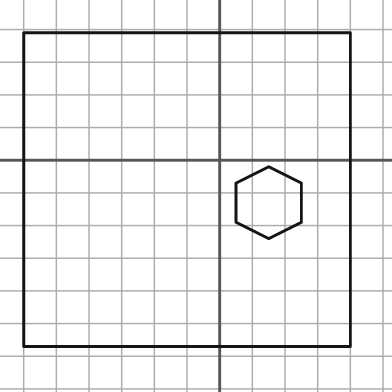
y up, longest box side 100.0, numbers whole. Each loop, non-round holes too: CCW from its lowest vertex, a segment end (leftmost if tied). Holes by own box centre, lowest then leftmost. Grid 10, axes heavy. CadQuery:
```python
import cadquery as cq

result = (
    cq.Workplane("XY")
    .moveTo(-60.0, -57.0)
    .lineTo(40.0, -57.0)
    .lineTo(40.0, 39.0)
    .lineTo(-60.0, 39.0)
    .close()
    .moveTo(15.0, -24.0)
    .lineTo(25.0, -19.0)
    .lineTo(25.0, -7.0)
    .lineTo(15.0, -2.0)
    .lineTo(5.0, -7.0)
    .lineTo(5.0, -19.0)
    .close()
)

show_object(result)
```